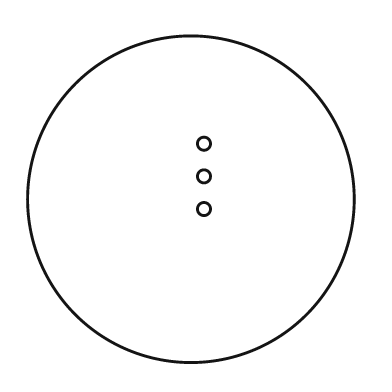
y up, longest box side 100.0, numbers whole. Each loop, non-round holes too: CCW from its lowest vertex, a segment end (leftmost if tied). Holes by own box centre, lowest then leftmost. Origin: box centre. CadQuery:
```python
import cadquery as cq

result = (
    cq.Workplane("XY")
    .moveTo(0.0, 0.0)
    .circle(50.0)
    .moveTo(4.0, -3.0)
    .circle(2.0)
    .moveTo(4.0, 7.0)
    .circle(2.0)
    .moveTo(4.0, 17.0)
    .circle(2.0)
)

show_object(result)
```